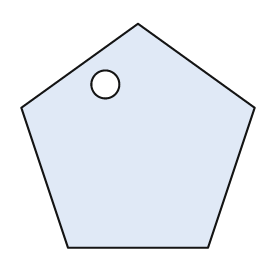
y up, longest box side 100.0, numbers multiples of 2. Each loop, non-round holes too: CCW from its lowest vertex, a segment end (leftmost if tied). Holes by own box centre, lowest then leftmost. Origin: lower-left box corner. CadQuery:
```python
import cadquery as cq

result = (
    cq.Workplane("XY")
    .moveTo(20.0, 0.0)
    .lineTo(80.0, 0.0)
    .lineTo(100.0, 60.0)
    .lineTo(50.0, 96.0)
    .lineTo(0.0, 60.0)
    .close()
    .moveTo(36.0, 70.0)
    .circle(6.0)
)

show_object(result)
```